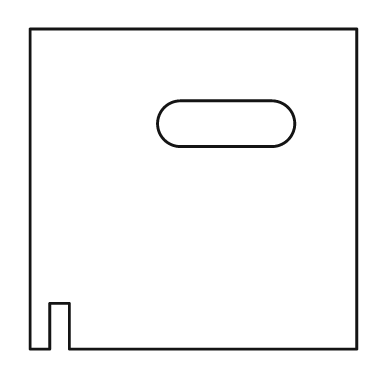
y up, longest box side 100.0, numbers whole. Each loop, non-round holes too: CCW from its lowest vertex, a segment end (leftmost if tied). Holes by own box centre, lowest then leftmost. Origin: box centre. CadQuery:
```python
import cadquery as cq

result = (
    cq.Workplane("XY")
    .moveTo(-50.0, -49.0)
    .lineTo(-44.0, -49.0)
    .lineTo(-44.0, -35.0)
    .lineTo(-38.0, -35.0)
    .lineTo(-38.0, -49.0)
    .lineTo(50.0, -49.0)
    .lineTo(50.0, 49.0)
    .lineTo(-50.0, 49.0)
    .close()
    .moveTo(-4.0, 13.0)
    .lineTo(24.0, 13.0)
    .threePointArc((31.0, 20.0), (24.0, 27.0))
    .lineTo(-4.0, 27.0)
    .threePointArc((-11.0, 20.0), (-4.0, 13.0))
    .close()
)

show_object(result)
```